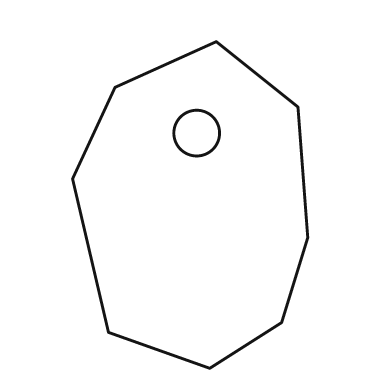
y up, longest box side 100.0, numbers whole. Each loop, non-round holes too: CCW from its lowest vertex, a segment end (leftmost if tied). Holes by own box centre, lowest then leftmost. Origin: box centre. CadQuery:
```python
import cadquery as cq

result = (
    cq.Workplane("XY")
    .moveTo(6.0, -50.0)
    .lineTo(28.0, -36.0)
    .lineTo(36.0, -10.0)
    .lineTo(33.0, 30.0)
    .lineTo(8.0, 50.0)
    .lineTo(-23.0, 36.0)
    .lineTo(-36.0, 8.0)
    .lineTo(-25.0, -39.0)
    .close()
    .moveTo(2.0, 22.0)
    .circle(7.0)
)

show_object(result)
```